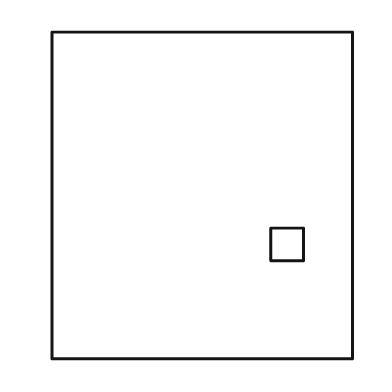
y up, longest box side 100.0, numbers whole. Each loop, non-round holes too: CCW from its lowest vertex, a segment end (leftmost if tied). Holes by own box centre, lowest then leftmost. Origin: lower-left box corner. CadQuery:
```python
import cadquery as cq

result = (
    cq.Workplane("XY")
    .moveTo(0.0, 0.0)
    .lineTo(92.0, 0.0)
    .lineTo(92.0, 100.0)
    .lineTo(0.0, 100.0)
    .close()
    .moveTo(67.0, 30.0)
    .lineTo(77.0, 30.0)
    .lineTo(77.0, 40.0)
    .lineTo(67.0, 40.0)
    .close()
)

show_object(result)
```